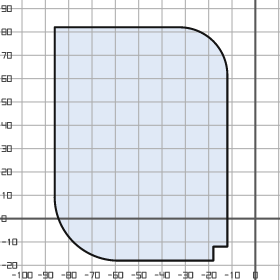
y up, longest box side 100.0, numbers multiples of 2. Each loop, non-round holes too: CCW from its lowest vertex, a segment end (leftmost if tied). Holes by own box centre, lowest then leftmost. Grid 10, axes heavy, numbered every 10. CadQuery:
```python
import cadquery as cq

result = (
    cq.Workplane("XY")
    .moveTo(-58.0, -18.0)
    .lineTo(-18.0, -18.0)
    .lineTo(-18.0, -12.0)
    .lineTo(-12.0, -12.0)
    .lineTo(-12.0, 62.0)
    .threePointArc((-18.0, 76.0), (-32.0, 82.0))
    .lineTo(-86.0, 82.0)
    .lineTo(-86.0, 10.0)
    .threePointArc((-78.0, -10.0), (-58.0, -18.0))
    .close()
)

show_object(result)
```